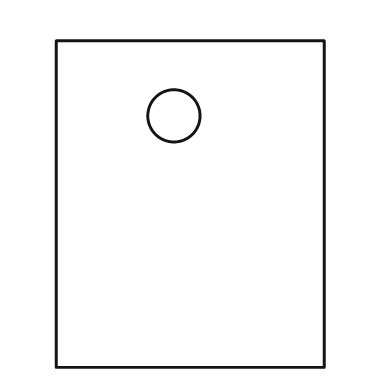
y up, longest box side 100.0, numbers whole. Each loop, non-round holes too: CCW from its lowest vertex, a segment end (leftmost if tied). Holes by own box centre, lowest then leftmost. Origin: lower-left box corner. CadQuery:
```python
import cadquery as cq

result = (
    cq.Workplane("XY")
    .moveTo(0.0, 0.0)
    .lineTo(82.0, 0.0)
    .lineTo(82.0, 100.0)
    .lineTo(0.0, 100.0)
    .close()
    .moveTo(36.0, 77.0)
    .circle(8.0)
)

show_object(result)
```